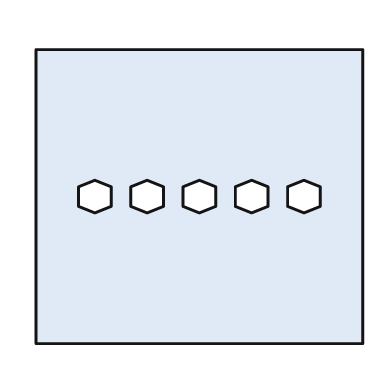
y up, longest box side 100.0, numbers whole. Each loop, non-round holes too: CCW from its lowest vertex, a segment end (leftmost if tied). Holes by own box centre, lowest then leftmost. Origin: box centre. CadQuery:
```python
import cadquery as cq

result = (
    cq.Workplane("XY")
    .moveTo(-50.0, -45.0)
    .lineTo(50.0, -45.0)
    .lineTo(50.0, 45.0)
    .lineTo(-50.0, 45.0)
    .close()
    .moveTo(-32.0, -5.0)
    .lineTo(-27.0, -3.0)
    .lineTo(-27.0, 3.0)
    .lineTo(-32.0, 5.0)
    .lineTo(-37.0, 3.0)
    .lineTo(-37.0, -3.0)
    .close()
    .moveTo(-16.0, -5.0)
    .lineTo(-11.0, -3.0)
    .lineTo(-11.0, 3.0)
    .lineTo(-16.0, 5.0)
    .lineTo(-21.0, 3.0)
    .lineTo(-21.0, -3.0)
    .close()
    .moveTo(0.0, -5.0)
    .lineTo(5.0, -3.0)
    .lineTo(5.0, 3.0)
    .lineTo(0.0, 5.0)
    .lineTo(-5.0, 3.0)
    .lineTo(-5.0, -3.0)
    .close()
    .moveTo(16.0, -5.0)
    .lineTo(21.0, -3.0)
    .lineTo(21.0, 3.0)
    .lineTo(16.0, 5.0)
    .lineTo(11.0, 3.0)
    .lineTo(11.0, -3.0)
    .close()
    .moveTo(32.0, -5.0)
    .lineTo(37.0, -3.0)
    .lineTo(37.0, 3.0)
    .lineTo(32.0, 5.0)
    .lineTo(27.0, 3.0)
    .lineTo(27.0, -3.0)
    .close()
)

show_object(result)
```